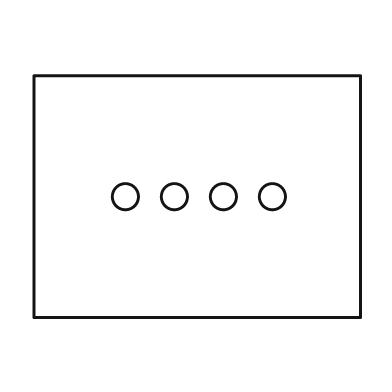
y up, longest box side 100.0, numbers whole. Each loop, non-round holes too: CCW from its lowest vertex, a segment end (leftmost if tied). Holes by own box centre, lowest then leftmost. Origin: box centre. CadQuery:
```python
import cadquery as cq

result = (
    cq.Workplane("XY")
    .moveTo(-50.0, -37.0)
    .lineTo(50.0, -37.0)
    .lineTo(50.0, 37.0)
    .lineTo(-50.0, 37.0)
    .close()
    .moveTo(-22.0, 0.0)
    .circle(4.0)
    .moveTo(-7.0, 0.0)
    .circle(4.0)
    .moveTo(8.0, 0.0)
    .circle(4.0)
    .moveTo(23.0, 0.0)
    .circle(4.0)
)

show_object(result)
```